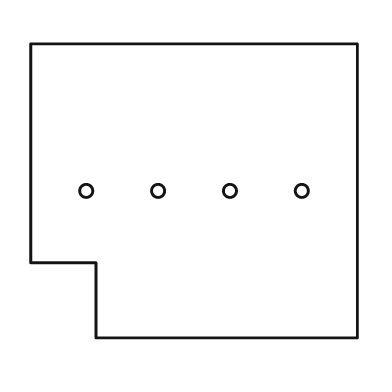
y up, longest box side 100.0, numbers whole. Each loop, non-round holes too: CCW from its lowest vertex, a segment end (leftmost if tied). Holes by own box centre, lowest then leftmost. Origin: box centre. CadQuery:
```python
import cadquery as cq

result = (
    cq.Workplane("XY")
    .moveTo(-30.0, -45.0)
    .lineTo(50.0, -45.0)
    .lineTo(50.0, 45.0)
    .lineTo(-50.0, 45.0)
    .lineTo(-50.0, -22.0)
    .lineTo(-30.0, -22.0)
    .close()
    .moveTo(-33.0, 0.0)
    .circle(2.0)
    .moveTo(-11.0, 0.0)
    .circle(2.0)
    .moveTo(11.0, 0.0)
    .circle(2.0)
    .moveTo(33.0, 0.0)
    .circle(2.0)
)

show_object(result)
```